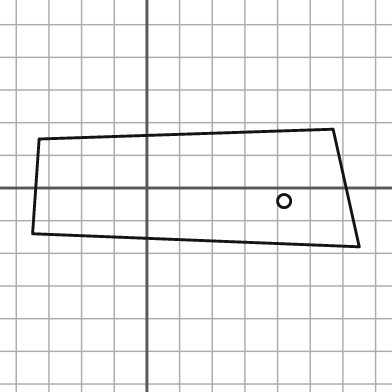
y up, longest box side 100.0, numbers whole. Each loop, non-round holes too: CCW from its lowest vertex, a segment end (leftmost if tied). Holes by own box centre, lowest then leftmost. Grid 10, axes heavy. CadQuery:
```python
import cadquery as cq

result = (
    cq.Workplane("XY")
    .moveTo(65.0, -18.0)
    .lineTo(57.0, 18.0)
    .lineTo(-33.0, 15.0)
    .lineTo(-35.0, -14.0)
    .close()
    .moveTo(42.0, -4.0)
    .circle(2.0)
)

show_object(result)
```